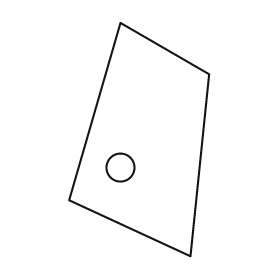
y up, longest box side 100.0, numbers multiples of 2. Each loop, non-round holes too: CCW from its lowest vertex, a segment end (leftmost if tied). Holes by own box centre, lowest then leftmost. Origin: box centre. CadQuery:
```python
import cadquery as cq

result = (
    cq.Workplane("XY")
    .moveTo(22.0, -50.0)
    .lineTo(30.0, 28.0)
    .lineTo(-8.0, 50.0)
    .lineTo(-30.0, -26.0)
    .close()
    .moveTo(-8.0, -12.0)
    .circle(6.0)
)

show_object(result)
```